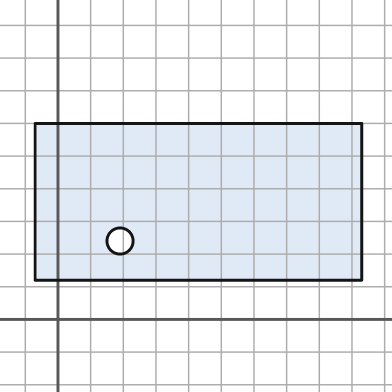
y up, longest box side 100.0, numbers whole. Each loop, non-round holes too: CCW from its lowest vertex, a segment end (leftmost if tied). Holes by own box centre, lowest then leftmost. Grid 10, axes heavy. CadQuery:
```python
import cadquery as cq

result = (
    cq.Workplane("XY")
    .moveTo(-7.0, 12.0)
    .lineTo(93.0, 12.0)
    .lineTo(93.0, 60.0)
    .lineTo(-7.0, 60.0)
    .close()
    .moveTo(19.0, 24.0)
    .circle(4.0)
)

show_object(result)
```